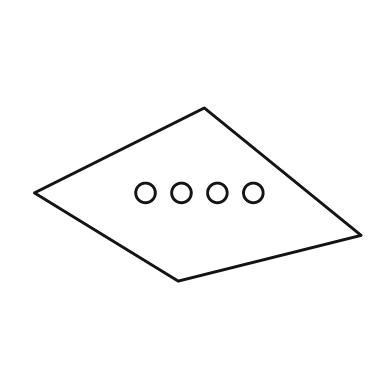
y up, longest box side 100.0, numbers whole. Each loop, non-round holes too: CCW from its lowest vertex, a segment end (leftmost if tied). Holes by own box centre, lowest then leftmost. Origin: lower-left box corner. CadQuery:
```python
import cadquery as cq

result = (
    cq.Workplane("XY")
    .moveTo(44.0, 0.0)
    .lineTo(100.0, 14.0)
    .lineTo(52.0, 53.0)
    .lineTo(0.0, 27.0)
    .close()
    .moveTo(34.0, 27.0)
    .circle(3.0)
    .moveTo(45.0, 27.0)
    .circle(3.0)
    .moveTo(56.0, 27.0)
    .circle(3.0)
    .moveTo(67.0, 27.0)
    .circle(3.0)
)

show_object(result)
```